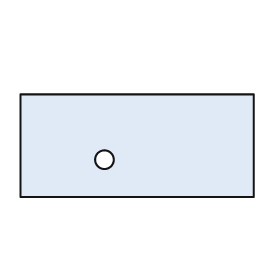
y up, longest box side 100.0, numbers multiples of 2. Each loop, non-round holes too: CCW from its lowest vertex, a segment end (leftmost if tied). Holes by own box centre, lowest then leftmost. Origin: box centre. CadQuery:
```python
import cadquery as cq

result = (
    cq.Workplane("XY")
    .moveTo(-50.0, -22.0)
    .lineTo(50.0, -22.0)
    .lineTo(50.0, 22.0)
    .lineTo(-50.0, 22.0)
    .close()
    .moveTo(-14.0, -6.0)
    .circle(4.0)
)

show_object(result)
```